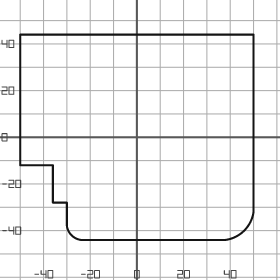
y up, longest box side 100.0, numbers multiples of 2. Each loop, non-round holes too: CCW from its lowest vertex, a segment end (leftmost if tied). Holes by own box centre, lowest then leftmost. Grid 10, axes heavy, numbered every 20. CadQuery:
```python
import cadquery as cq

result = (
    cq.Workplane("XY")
    .moveTo(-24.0, -44.0)
    .lineTo(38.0, -44.0)
    .threePointArc((46.0, -40.0), (50.0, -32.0))
    .lineTo(50.0, 44.0)
    .lineTo(-50.0, 44.0)
    .lineTo(-50.0, -12.0)
    .lineTo(-36.0, -12.0)
    .lineTo(-36.0, -28.0)
    .lineTo(-30.0, -28.0)
    .lineTo(-30.0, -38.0)
    .threePointArc((-28.0, -42.0), (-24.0, -44.0))
    .close()
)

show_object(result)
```